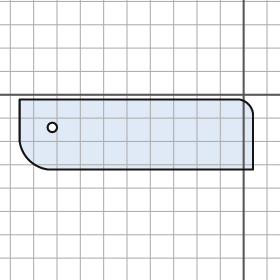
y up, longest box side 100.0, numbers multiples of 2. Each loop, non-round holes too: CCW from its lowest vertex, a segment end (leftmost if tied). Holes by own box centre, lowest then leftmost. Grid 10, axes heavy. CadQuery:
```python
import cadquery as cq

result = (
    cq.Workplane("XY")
    .moveTo(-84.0, -32.0)
    .lineTo(4.0, -32.0)
    .lineTo(4.0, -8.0)
    .threePointArc((2.0, -4.0), (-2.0, -2.0))
    .lineTo(-96.0, -2.0)
    .lineTo(-96.0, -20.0)
    .threePointArc((-92.0, -28.0), (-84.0, -32.0))
    .close()
    .moveTo(-82.0, -14.0)
    .circle(2.0)
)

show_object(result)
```